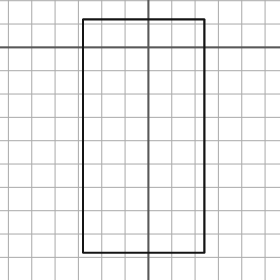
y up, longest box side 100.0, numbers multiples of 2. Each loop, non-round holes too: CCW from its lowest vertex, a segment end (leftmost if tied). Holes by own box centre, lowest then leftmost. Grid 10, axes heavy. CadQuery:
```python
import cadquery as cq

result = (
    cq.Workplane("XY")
    .moveTo(-28.0, -88.0)
    .lineTo(24.0, -88.0)
    .lineTo(24.0, 12.0)
    .lineTo(-28.0, 12.0)
    .close()
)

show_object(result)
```